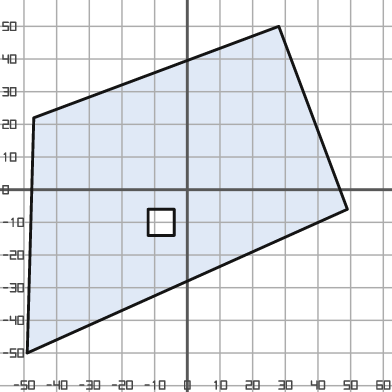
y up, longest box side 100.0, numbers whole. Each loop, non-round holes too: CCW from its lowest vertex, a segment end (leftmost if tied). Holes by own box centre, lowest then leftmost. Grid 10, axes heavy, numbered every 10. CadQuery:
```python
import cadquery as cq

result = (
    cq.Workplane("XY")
    .moveTo(-49.0, -50.0)
    .lineTo(49.0, -6.0)
    .lineTo(28.0, 50.0)
    .lineTo(-47.0, 22.0)
    .close()
    .moveTo(-12.0, -14.0)
    .lineTo(-4.0, -14.0)
    .lineTo(-4.0, -6.0)
    .lineTo(-12.0, -6.0)
    .close()
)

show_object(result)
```